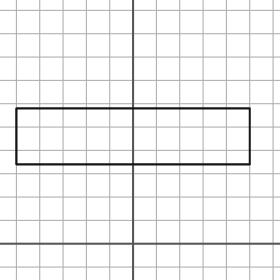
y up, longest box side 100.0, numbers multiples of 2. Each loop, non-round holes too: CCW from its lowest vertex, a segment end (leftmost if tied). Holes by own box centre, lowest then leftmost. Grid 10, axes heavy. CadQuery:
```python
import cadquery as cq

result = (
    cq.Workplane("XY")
    .moveTo(-50.0, 34.0)
    .lineTo(50.0, 34.0)
    .lineTo(50.0, 58.0)
    .lineTo(-50.0, 58.0)
    .close()
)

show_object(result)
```